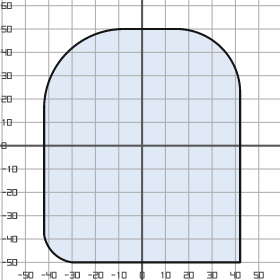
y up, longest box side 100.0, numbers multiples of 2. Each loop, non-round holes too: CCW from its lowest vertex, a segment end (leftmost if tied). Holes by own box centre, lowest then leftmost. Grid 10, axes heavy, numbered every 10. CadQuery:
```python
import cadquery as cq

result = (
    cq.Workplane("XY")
    .moveTo(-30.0, -50.0)
    .lineTo(42.0, -50.0)
    .lineTo(42.0, 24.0)
    .threePointArc((34.0, 42.0), (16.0, 50.0))
    .lineTo(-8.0, 50.0)
    .threePointArc((-32.0, 40.0), (-42.0, 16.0))
    .lineTo(-42.0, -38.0)
    .threePointArc((-38.0, -46.0), (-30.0, -50.0))
    .close()
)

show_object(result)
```